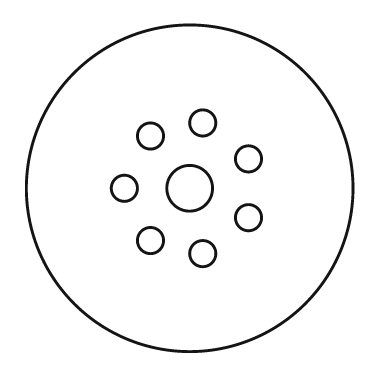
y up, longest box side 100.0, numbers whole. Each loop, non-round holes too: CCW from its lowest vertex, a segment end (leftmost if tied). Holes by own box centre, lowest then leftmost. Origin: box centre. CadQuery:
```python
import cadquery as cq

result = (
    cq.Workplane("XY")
    .moveTo(0.0, 0.0)
    .circle(50.0)
    .moveTo(4.0, -20.0)
    .circle(4.0)
    .moveTo(-12.0, -16.0)
    .circle(4.0)
    .moveTo(18.0, -9.0)
    .circle(4.0)
    .moveTo(-20.0, 0.0)
    .circle(4.0)
    .moveTo(0.0, 0.0)
    .circle(7.0)
    .moveTo(18.0, 9.0)
    .circle(4.0)
    .moveTo(-12.0, 16.0)
    .circle(4.0)
    .moveTo(4.0, 20.0)
    .circle(4.0)
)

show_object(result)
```